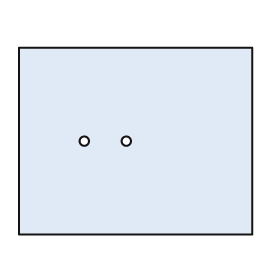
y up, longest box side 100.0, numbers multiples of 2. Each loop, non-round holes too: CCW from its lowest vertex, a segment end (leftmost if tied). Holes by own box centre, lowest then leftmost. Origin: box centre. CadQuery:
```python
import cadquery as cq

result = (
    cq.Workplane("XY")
    .moveTo(-50.0, -40.0)
    .lineTo(50.0, -40.0)
    .lineTo(50.0, 40.0)
    .lineTo(-50.0, 40.0)
    .close()
    .moveTo(-22.0, 0.0)
    .circle(2.0)
    .moveTo(-4.0, 0.0)
    .circle(2.0)
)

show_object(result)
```